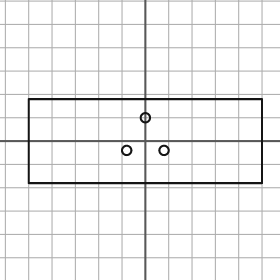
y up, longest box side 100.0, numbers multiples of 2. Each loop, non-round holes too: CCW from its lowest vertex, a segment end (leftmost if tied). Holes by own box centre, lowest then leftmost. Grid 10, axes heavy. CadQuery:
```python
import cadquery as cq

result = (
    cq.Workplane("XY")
    .moveTo(-50.0, -18.0)
    .lineTo(50.0, -18.0)
    .lineTo(50.0, 18.0)
    .lineTo(-50.0, 18.0)
    .close()
    .moveTo(-8.0, -4.0)
    .circle(2.0)
    .moveTo(8.0, -4.0)
    .circle(2.0)
    .moveTo(0.0, 10.0)
    .circle(2.0)
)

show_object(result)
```